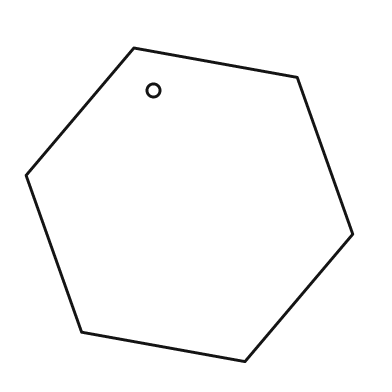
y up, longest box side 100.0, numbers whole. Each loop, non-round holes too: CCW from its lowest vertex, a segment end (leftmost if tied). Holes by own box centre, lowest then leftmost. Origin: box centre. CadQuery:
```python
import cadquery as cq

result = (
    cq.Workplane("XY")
    .moveTo(17.0, -48.0)
    .lineTo(50.0, -9.0)
    .lineTo(33.0, 39.0)
    .lineTo(-17.0, 48.0)
    .lineTo(-50.0, 9.0)
    .lineTo(-33.0, -39.0)
    .close()
    .moveTo(-11.0, 35.0)
    .circle(2.0)
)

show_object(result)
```